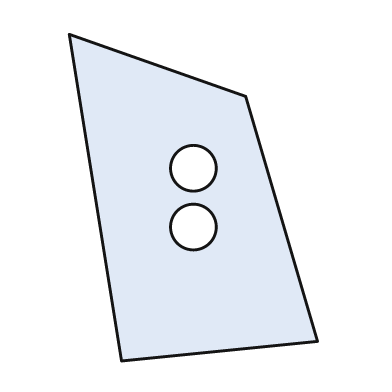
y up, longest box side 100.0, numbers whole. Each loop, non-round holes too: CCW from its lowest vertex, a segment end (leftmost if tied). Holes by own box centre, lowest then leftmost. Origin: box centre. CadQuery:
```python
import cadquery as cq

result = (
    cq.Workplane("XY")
    .moveTo(-22.0, -50.0)
    .lineTo(38.0, -44.0)
    .lineTo(16.0, 31.0)
    .lineTo(-38.0, 50.0)
    .close()
    .moveTo(0.0, -9.0)
    .circle(7.0)
    .moveTo(0.0, 9.0)
    .circle(7.0)
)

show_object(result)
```